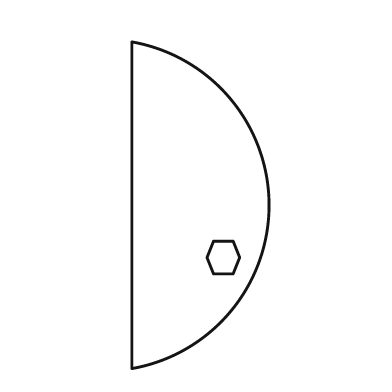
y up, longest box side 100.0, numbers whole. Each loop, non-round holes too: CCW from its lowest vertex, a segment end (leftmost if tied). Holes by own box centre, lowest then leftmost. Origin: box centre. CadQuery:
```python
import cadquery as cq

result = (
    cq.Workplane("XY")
    .moveTo(-21.0, -50.0)
    .threePointArc((21.0, 0.0), (-21.0, 50.0))
    .close()
    .moveTo(4.0, -21.0)
    .lineTo(10.0, -21.0)
    .lineTo(12.0, -16.0)
    .lineTo(10.0, -11.0)
    .lineTo(4.0, -11.0)
    .lineTo(2.0, -16.0)
    .close()
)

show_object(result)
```